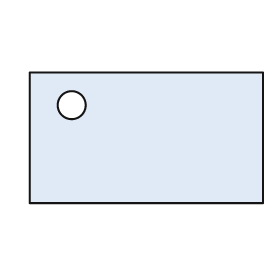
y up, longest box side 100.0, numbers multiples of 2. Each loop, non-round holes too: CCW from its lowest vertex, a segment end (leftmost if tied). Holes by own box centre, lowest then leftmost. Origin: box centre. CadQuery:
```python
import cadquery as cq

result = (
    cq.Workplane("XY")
    .moveTo(-50.0, -28.0)
    .lineTo(50.0, -28.0)
    .lineTo(50.0, 28.0)
    .lineTo(-50.0, 28.0)
    .close()
    .moveTo(-32.0, 14.0)
    .circle(6.0)
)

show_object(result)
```